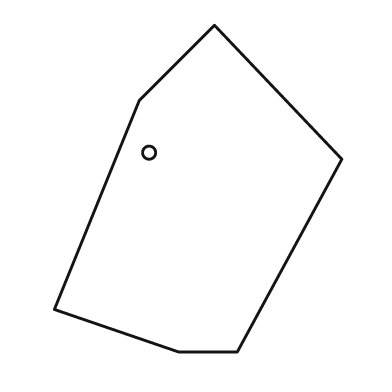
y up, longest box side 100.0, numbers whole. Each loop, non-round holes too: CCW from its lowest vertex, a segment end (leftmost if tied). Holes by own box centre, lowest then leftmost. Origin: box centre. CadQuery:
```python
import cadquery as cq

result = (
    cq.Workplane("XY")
    .moveTo(-6.0, -50.0)
    .lineTo(12.0, -50.0)
    .lineTo(44.0, 9.0)
    .lineTo(5.0, 50.0)
    .lineTo(-18.0, 27.0)
    .lineTo(-44.0, -37.0)
    .close()
    .moveTo(-15.0, 11.0)
    .circle(2.0)
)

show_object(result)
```